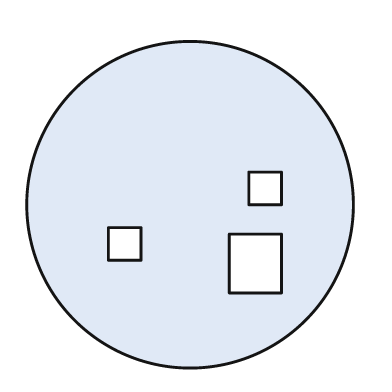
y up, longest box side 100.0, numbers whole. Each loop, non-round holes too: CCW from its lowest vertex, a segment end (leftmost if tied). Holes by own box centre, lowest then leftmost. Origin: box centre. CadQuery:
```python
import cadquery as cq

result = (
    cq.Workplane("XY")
    .moveTo(0.0, 0.0)
    .circle(50.0)
    .moveTo(12.0, -27.0)
    .lineTo(28.0, -27.0)
    .lineTo(28.0, -9.0)
    .lineTo(12.0, -9.0)
    .close()
    .moveTo(-25.0, -17.0)
    .lineTo(-15.0, -17.0)
    .lineTo(-15.0, -7.0)
    .lineTo(-25.0, -7.0)
    .close()
    .moveTo(18.0, 0.0)
    .lineTo(28.0, 0.0)
    .lineTo(28.0, 10.0)
    .lineTo(18.0, 10.0)
    .close()
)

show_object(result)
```